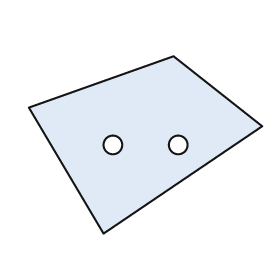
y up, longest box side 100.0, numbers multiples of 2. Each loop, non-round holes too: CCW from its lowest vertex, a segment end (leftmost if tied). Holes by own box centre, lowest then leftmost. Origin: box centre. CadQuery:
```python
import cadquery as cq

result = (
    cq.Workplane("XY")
    .moveTo(-18.0, -38.0)
    .lineTo(50.0, 8.0)
    .lineTo(12.0, 38.0)
    .lineTo(-50.0, 16.0)
    .close()
    .moveTo(-14.0, 0.0)
    .circle(4.0)
    .moveTo(14.0, 0.0)
    .circle(4.0)
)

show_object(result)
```